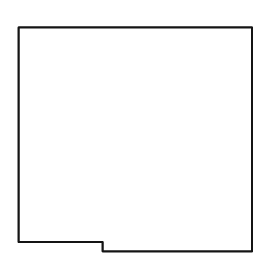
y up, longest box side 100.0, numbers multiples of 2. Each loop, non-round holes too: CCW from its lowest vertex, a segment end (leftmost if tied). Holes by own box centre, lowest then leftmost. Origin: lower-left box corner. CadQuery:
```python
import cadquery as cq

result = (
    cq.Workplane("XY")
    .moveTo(36.0, 0.0)
    .lineTo(100.0, 0.0)
    .lineTo(100.0, 96.0)
    .lineTo(0.0, 96.0)
    .lineTo(0.0, 4.0)
    .lineTo(36.0, 4.0)
    .close()
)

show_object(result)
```